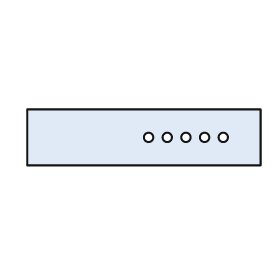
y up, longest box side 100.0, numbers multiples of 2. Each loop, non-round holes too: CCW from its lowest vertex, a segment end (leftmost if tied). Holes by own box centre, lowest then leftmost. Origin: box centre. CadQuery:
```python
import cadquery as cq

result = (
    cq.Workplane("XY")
    .moveTo(-50.0, -12.0)
    .lineTo(50.0, -12.0)
    .lineTo(50.0, 12.0)
    .lineTo(-50.0, 12.0)
    .close()
    .moveTo(2.0, 0.0)
    .circle(2.0)
    .moveTo(10.0, 0.0)
    .circle(2.0)
    .moveTo(18.0, 0.0)
    .circle(2.0)
    .moveTo(26.0, 0.0)
    .circle(2.0)
    .moveTo(34.0, 0.0)
    .circle(2.0)
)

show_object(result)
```